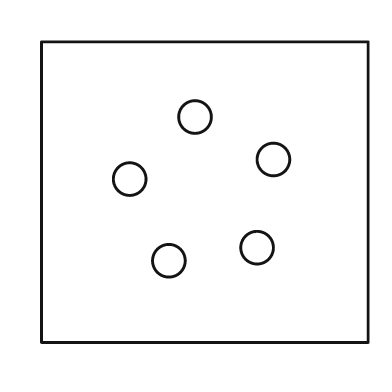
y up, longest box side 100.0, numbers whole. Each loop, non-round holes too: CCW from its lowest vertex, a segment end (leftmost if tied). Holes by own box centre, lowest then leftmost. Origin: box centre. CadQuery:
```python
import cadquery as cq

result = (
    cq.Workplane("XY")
    .moveTo(-50.0, -46.0)
    .lineTo(50.0, -46.0)
    .lineTo(50.0, 46.0)
    .lineTo(-50.0, 46.0)
    .close()
    .moveTo(-11.0, -21.0)
    .circle(5.0)
    .moveTo(16.0, -17.0)
    .circle(5.0)
    .moveTo(-23.0, 4.0)
    .circle(5.0)
    .moveTo(21.0, 10.0)
    .circle(5.0)
    .moveTo(-3.0, 23.0)
    .circle(5.0)
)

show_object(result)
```